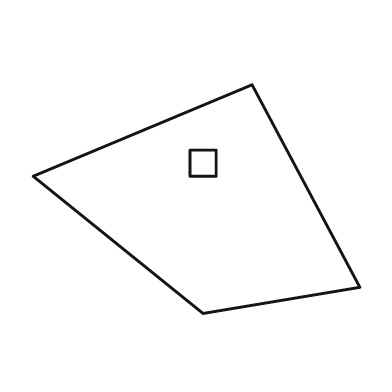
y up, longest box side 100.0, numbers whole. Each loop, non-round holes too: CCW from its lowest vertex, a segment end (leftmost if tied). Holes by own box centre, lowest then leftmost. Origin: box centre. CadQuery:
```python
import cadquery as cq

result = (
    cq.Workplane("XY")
    .moveTo(2.0, -35.0)
    .lineTo(50.0, -27.0)
    .lineTo(17.0, 35.0)
    .lineTo(-50.0, 7.0)
    .close()
    .moveTo(-2.0, 7.0)
    .lineTo(6.0, 7.0)
    .lineTo(6.0, 15.0)
    .lineTo(-2.0, 15.0)
    .close()
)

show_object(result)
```